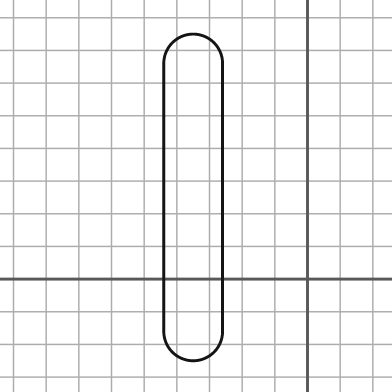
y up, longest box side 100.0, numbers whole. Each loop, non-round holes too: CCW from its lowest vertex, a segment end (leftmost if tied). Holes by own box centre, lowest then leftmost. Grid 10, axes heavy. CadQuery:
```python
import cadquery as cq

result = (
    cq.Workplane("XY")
    .moveTo(-44.0, -16.0)
    .threePointArc((-35.0, -25.0), (-26.0, -16.0))
    .lineTo(-26.0, 66.0)
    .threePointArc((-35.0, 75.0), (-44.0, 66.0))
    .close()
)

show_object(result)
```